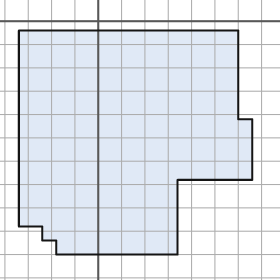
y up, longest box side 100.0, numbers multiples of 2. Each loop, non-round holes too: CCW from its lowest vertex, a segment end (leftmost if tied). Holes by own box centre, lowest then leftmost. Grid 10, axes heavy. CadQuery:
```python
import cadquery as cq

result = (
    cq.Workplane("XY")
    .moveTo(-18.0, -100.0)
    .lineTo(34.0, -100.0)
    .lineTo(34.0, -68.0)
    .lineTo(66.0, -68.0)
    .lineTo(66.0, -42.0)
    .lineTo(60.0, -42.0)
    .lineTo(60.0, -4.0)
    .lineTo(-34.0, -4.0)
    .lineTo(-34.0, -88.0)
    .lineTo(-24.0, -88.0)
    .lineTo(-24.0, -94.0)
    .lineTo(-18.0, -94.0)
    .close()
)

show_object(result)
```